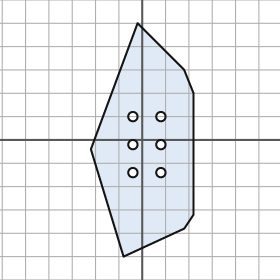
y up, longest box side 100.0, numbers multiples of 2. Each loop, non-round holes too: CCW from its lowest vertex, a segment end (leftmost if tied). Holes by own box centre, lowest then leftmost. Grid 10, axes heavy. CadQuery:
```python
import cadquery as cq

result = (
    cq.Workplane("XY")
    .moveTo(-8.0, -50.0)
    .lineTo(18.0, -38.0)
    .lineTo(22.0, -32.0)
    .lineTo(22.0, 20.0)
    .lineTo(18.0, 30.0)
    .lineTo(-2.0, 50.0)
    .lineTo(-22.0, -4.0)
    .close()
    .moveTo(-4.0, -14.0)
    .circle(2.0)
    .moveTo(8.0, -14.0)
    .circle(2.0)
    .moveTo(-4.0, -2.0)
    .circle(2.0)
    .moveTo(8.0, -2.0)
    .circle(2.0)
    .moveTo(-4.0, 10.0)
    .circle(2.0)
    .moveTo(8.0, 10.0)
    .circle(2.0)
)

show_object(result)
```